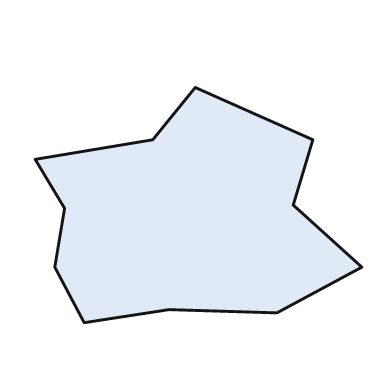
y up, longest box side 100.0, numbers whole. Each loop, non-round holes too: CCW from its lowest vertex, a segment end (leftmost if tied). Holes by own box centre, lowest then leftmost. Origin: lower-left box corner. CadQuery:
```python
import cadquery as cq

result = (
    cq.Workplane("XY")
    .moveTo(15.0, 0.0)
    .lineTo(41.0, 4.0)
    .lineTo(74.0, 3.0)
    .lineTo(100.0, 17.0)
    .lineTo(79.0, 36.0)
    .lineTo(85.0, 56.0)
    .lineTo(49.0, 72.0)
    .lineTo(36.0, 56.0)
    .lineTo(0.0, 50.0)
    .lineTo(9.0, 35.0)
    .lineTo(6.0, 17.0)
    .close()
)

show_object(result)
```